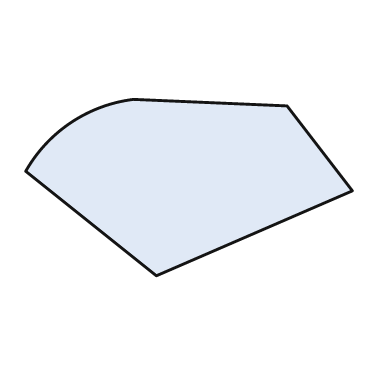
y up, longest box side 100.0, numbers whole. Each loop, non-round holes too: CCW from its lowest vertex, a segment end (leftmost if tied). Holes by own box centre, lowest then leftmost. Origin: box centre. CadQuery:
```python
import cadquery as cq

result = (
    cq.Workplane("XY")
    .moveTo(-10.0, -27.0)
    .lineTo(50.0, -1.0)
    .lineTo(30.0, 25.0)
    .lineTo(-17.0, 27.0)
    .threePointArc((-36.0, 20.0), (-50.0, 5.0))
    .close()
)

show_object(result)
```